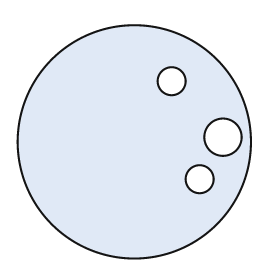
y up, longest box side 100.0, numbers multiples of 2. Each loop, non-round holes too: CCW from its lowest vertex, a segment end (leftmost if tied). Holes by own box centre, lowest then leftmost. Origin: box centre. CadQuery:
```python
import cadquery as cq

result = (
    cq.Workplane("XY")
    .moveTo(0.0, 0.0)
    .circle(50.0)
    .moveTo(28.0, -16.0)
    .circle(6.0)
    .moveTo(38.0, 2.0)
    .circle(8.0)
    .moveTo(16.0, 26.0)
    .circle(6.0)
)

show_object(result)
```